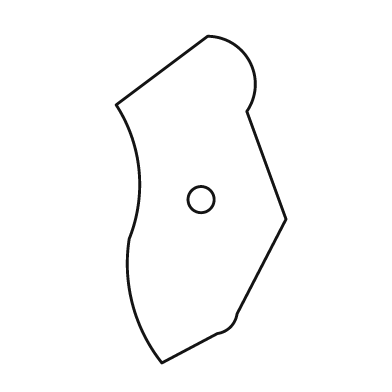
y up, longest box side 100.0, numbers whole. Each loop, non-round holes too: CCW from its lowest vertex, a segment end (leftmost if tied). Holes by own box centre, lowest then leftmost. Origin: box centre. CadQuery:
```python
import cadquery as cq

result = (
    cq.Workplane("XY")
    .moveTo(-12.0, -50.0)
    .lineTo(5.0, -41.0)
    .threePointArc((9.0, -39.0), (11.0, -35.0))
    .lineTo(26.0, -6.0)
    .lineTo(14.0, 27.0)
    .threePointArc((15.0, 42.0), (2.0, 50.0))
    .lineTo(-26.0, 29.0)
    .threePointArc((-19.0, 9.0), (-22.0, -12.0))
    .threePointArc((-21.0, -32.0), (-12.0, -50.0))
    .close()
    .moveTo(0.0, 0.0)
    .circle(4.0)
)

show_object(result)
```